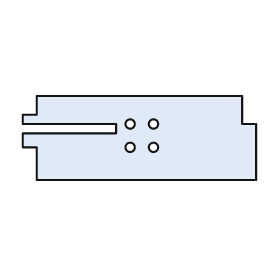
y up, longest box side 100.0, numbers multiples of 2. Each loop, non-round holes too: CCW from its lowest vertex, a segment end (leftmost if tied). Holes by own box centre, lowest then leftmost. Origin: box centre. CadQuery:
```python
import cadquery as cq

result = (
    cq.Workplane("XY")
    .moveTo(-44.0, -18.0)
    .lineTo(50.0, -18.0)
    .lineTo(50.0, 6.0)
    .lineTo(44.0, 6.0)
    .lineTo(44.0, 18.0)
    .lineTo(-44.0, 18.0)
    .lineTo(-44.0, 10.0)
    .lineTo(-50.0, 10.0)
    .lineTo(-50.0, 6.0)
    .lineTo(-10.0, 6.0)
    .lineTo(-10.0, 2.0)
    .lineTo(-50.0, 2.0)
    .lineTo(-50.0, -4.0)
    .lineTo(-44.0, -4.0)
    .close()
    .moveTo(-4.0, -4.0)
    .circle(2.0)
    .moveTo(6.0, -4.0)
    .circle(2.0)
    .moveTo(-4.0, 6.0)
    .circle(2.0)
    .moveTo(6.0, 6.0)
    .circle(2.0)
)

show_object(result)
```